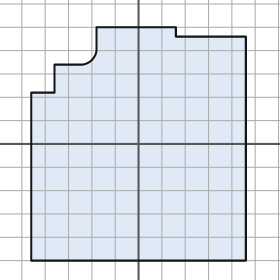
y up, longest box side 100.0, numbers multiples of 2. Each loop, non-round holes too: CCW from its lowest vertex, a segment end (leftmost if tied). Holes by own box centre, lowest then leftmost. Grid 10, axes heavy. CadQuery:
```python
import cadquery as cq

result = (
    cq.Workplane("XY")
    .moveTo(-46.0, -50.0)
    .lineTo(46.0, -50.0)
    .lineTo(46.0, 46.0)
    .lineTo(16.0, 46.0)
    .lineTo(16.0, 50.0)
    .lineTo(-18.0, 50.0)
    .lineTo(-18.0, 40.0)
    .threePointArc((-20.0, 36.0), (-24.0, 34.0))
    .lineTo(-36.0, 34.0)
    .lineTo(-36.0, 22.0)
    .lineTo(-46.0, 22.0)
    .close()
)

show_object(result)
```